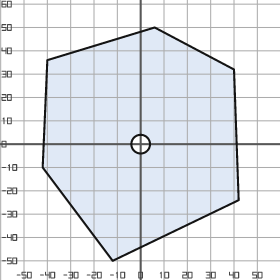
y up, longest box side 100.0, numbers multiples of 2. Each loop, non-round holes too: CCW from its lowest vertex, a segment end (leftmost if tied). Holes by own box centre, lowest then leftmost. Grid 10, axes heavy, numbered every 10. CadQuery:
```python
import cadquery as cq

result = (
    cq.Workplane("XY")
    .moveTo(-12.0, -50.0)
    .lineTo(42.0, -24.0)
    .lineTo(40.0, 32.0)
    .lineTo(6.0, 50.0)
    .lineTo(-40.0, 36.0)
    .lineTo(-42.0, -10.0)
    .close()
    .moveTo(0.0, 0.0)
    .circle(4.0)
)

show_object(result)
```